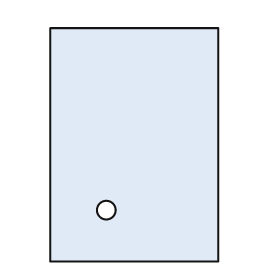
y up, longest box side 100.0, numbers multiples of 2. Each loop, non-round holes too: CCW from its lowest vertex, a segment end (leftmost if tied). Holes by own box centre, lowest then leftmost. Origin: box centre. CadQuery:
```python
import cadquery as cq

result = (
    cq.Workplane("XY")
    .moveTo(-36.0, -50.0)
    .lineTo(36.0, -50.0)
    .lineTo(36.0, 50.0)
    .lineTo(-36.0, 50.0)
    .close()
    .moveTo(-12.0, -28.0)
    .circle(4.0)
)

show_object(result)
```